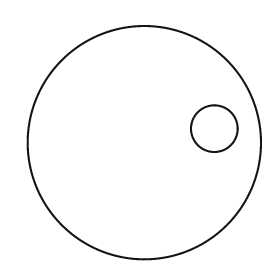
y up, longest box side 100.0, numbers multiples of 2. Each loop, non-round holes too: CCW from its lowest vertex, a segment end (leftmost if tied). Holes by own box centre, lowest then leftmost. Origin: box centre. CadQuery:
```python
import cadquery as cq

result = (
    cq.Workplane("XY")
    .moveTo(0.0, 0.0)
    .circle(50.0)
    .moveTo(30.0, 6.0)
    .circle(10.0)
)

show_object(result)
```